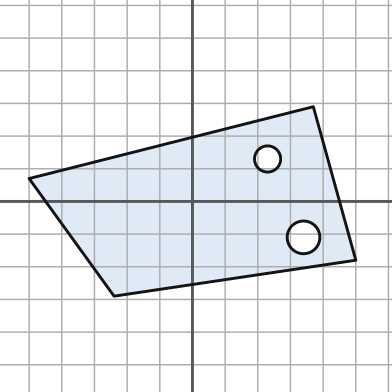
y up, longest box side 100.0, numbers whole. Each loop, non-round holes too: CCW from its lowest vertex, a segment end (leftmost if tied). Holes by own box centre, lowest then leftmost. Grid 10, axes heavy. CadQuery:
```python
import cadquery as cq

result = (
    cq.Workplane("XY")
    .moveTo(-24.0, -29.0)
    .lineTo(50.0, -18.0)
    .lineTo(37.0, 29.0)
    .lineTo(-50.0, 7.0)
    .close()
    .moveTo(34.0, -11.0)
    .circle(5.0)
    .moveTo(23.0, 13.0)
    .circle(4.0)
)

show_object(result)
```